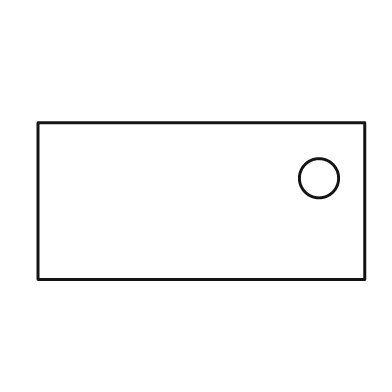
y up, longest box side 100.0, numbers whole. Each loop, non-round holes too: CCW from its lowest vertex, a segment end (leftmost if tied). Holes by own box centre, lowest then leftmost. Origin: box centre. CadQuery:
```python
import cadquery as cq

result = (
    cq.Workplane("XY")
    .moveTo(-50.0, -24.0)
    .lineTo(50.0, -24.0)
    .lineTo(50.0, 24.0)
    .lineTo(-50.0, 24.0)
    .close()
    .moveTo(36.0, 7.0)
    .circle(6.0)
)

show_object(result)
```